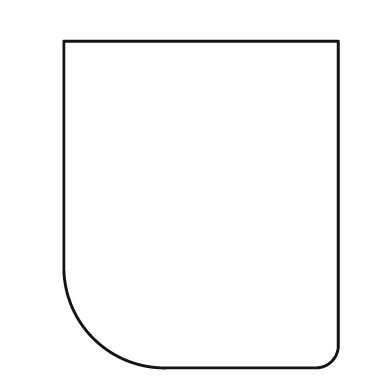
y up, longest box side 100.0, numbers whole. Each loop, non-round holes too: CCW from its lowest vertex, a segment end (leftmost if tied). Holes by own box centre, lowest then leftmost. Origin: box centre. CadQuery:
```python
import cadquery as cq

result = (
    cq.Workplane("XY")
    .moveTo(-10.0, -50.0)
    .lineTo(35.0, -50.0)
    .threePointArc((40.0, -48.0), (42.0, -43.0))
    .lineTo(42.0, 50.0)
    .lineTo(-42.0, 50.0)
    .lineTo(-42.0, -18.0)
    .threePointArc((-33.0, -41.0), (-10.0, -50.0))
    .close()
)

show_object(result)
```